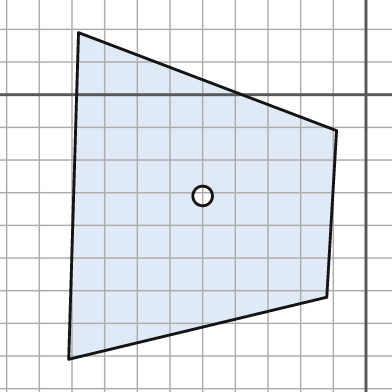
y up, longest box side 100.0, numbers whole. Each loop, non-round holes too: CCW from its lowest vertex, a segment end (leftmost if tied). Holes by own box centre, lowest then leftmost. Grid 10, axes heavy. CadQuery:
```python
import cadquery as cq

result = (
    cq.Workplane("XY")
    .moveTo(-91.0, -81.0)
    .lineTo(-12.0, -62.0)
    .lineTo(-9.0, -11.0)
    .lineTo(-88.0, 19.0)
    .close()
    .moveTo(-50.0, -31.0)
    .circle(3.0)
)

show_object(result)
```